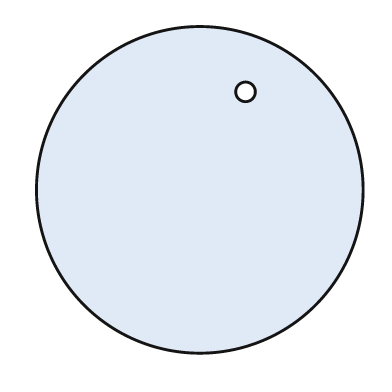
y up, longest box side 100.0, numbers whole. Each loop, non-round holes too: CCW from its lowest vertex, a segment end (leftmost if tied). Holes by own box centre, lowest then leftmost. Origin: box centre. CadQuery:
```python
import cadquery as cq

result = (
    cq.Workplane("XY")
    .moveTo(0.0, 0.0)
    .circle(50.0)
    .moveTo(14.0, 30.0)
    .circle(3.0)
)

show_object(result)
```